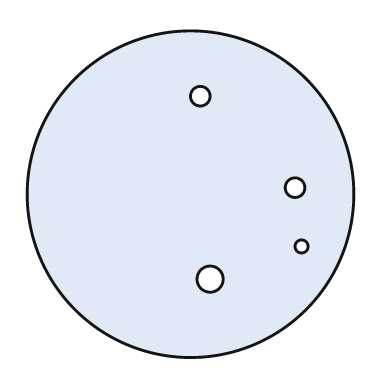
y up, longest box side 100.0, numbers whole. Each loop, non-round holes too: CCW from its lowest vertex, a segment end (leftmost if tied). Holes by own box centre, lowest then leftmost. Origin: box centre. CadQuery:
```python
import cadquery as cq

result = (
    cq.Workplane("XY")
    .moveTo(0.0, 0.0)
    .circle(50.0)
    .moveTo(6.0, -26.0)
    .circle(4.0)
    .moveTo(34.0, -16.0)
    .circle(2.0)
    .moveTo(32.0, 2.0)
    .circle(3.0)
    .moveTo(3.0, 30.0)
    .circle(3.0)
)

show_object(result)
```